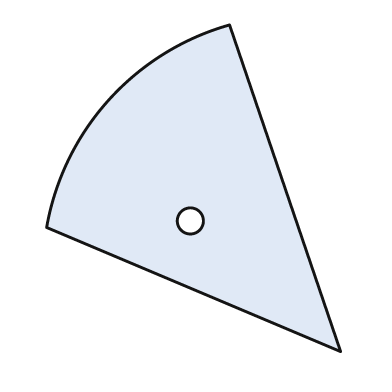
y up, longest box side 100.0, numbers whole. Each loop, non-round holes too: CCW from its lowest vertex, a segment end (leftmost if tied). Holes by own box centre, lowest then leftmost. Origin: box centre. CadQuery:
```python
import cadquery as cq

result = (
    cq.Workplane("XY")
    .moveTo(45.0, -50.0)
    .lineTo(11.0, 50.0)
    .threePointArc((-26.0, 27.0), (-45.0, -12.0))
    .close()
    .moveTo(-1.0, -10.0)
    .circle(4.0)
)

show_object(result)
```